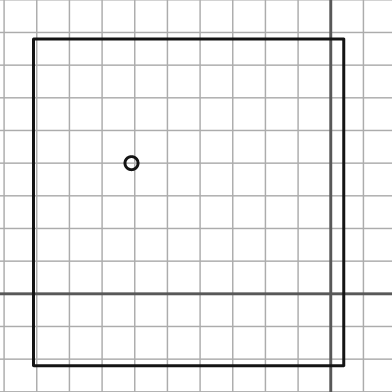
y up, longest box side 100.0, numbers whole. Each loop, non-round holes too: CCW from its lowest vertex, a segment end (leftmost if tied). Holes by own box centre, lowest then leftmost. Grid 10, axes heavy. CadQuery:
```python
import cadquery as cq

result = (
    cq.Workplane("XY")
    .moveTo(-91.0, -22.0)
    .lineTo(4.0, -22.0)
    .lineTo(4.0, 78.0)
    .lineTo(-91.0, 78.0)
    .close()
    .moveTo(-61.0, 40.0)
    .circle(2.0)
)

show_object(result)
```